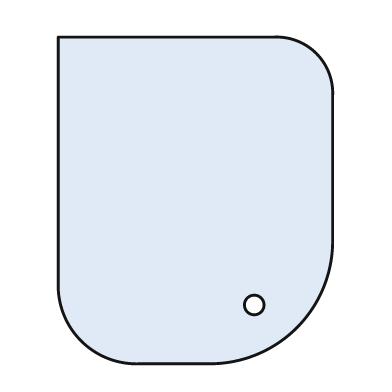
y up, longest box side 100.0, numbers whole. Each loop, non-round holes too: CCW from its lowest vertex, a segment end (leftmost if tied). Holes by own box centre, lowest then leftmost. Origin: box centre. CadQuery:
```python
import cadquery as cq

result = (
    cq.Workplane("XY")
    .moveTo(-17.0, -50.0)
    .lineTo(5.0, -50.0)
    .threePointArc((31.0, -39.0), (42.0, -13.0))
    .lineTo(42.0, 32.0)
    .threePointArc((37.0, 45.0), (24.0, 50.0))
    .lineTo(-42.0, 50.0)
    .lineTo(-42.0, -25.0)
    .threePointArc((-35.0, -43.0), (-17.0, -50.0))
    .close()
    .moveTo(18.0, -32.0)
    .circle(3.0)
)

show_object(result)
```